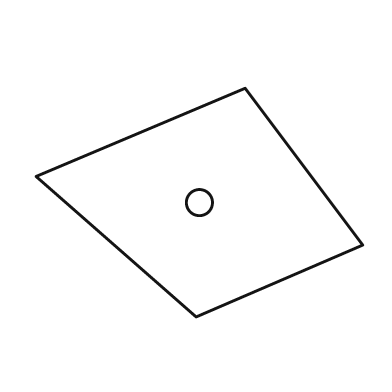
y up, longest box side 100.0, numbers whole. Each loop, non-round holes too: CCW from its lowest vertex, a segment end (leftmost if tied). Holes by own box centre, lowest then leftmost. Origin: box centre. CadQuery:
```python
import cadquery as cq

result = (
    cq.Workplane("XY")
    .moveTo(-1.0, -35.0)
    .lineTo(50.0, -13.0)
    .lineTo(14.0, 35.0)
    .lineTo(-50.0, 8.0)
    .close()
    .moveTo(0.0, 0.0)
    .circle(4.0)
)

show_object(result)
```